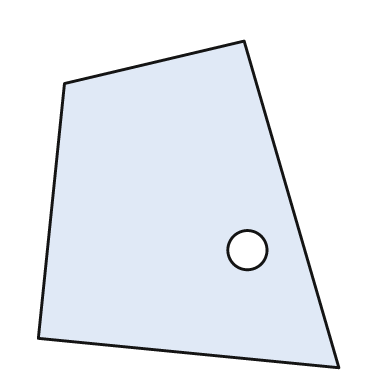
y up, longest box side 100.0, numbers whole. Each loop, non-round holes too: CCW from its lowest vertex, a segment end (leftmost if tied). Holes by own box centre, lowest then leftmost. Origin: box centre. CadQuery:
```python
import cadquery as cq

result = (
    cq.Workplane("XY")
    .moveTo(46.0, -50.0)
    .lineTo(17.0, 50.0)
    .lineTo(-38.0, 37.0)
    .lineTo(-46.0, -41.0)
    .close()
    .moveTo(18.0, -14.0)
    .circle(6.0)
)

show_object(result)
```